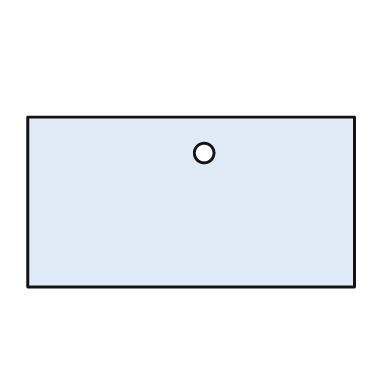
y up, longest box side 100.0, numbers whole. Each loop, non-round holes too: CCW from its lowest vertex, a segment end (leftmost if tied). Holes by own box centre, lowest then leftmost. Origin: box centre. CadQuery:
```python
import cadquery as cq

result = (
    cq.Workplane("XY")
    .moveTo(-50.0, -26.0)
    .lineTo(50.0, -26.0)
    .lineTo(50.0, 26.0)
    .lineTo(-50.0, 26.0)
    .close()
    .moveTo(4.0, 15.0)
    .circle(3.0)
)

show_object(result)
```